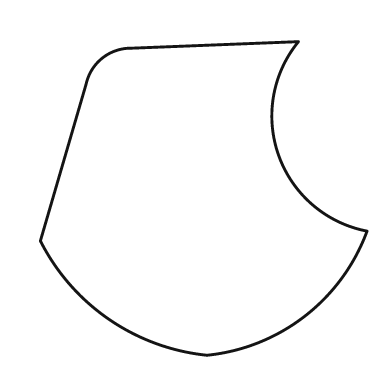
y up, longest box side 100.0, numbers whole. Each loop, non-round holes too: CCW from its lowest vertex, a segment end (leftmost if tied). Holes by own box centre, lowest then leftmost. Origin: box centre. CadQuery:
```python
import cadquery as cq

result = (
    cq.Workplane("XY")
    .moveTo(1.0, -48.0)
    .threePointArc((31.0, -36.0), (50.0, -10.0))
    .threePointArc((23.0, 13.0), (29.0, 48.0))
    .lineTo(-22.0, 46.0)
    .threePointArc((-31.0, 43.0), (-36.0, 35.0))
    .lineTo(-50.0, -13.0)
    .threePointArc((-29.0, -37.0), (1.0, -48.0))
    .close()
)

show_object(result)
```